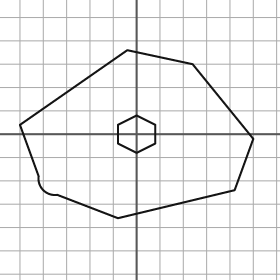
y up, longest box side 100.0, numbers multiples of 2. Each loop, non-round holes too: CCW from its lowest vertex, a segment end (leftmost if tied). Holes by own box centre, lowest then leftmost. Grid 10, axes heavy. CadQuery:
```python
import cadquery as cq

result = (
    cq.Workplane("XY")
    .moveTo(-8.0, -36.0)
    .lineTo(42.0, -24.0)
    .lineTo(50.0, -2.0)
    .lineTo(24.0, 30.0)
    .lineTo(-4.0, 36.0)
    .lineTo(-50.0, 4.0)
    .lineTo(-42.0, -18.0)
    .threePointArc((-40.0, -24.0), (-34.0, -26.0))
    .close()
    .moveTo(0.0, -8.0)
    .lineTo(8.0, -4.0)
    .lineTo(8.0, 4.0)
    .lineTo(0.0, 8.0)
    .lineTo(-8.0, 4.0)
    .lineTo(-8.0, -4.0)
    .close()
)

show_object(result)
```